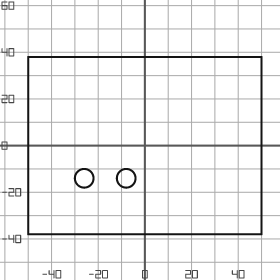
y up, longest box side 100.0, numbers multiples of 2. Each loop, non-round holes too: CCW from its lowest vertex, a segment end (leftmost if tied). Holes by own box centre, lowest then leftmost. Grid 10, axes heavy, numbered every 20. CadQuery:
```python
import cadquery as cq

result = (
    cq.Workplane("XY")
    .moveTo(-50.0, -38.0)
    .lineTo(50.0, -38.0)
    .lineTo(50.0, 38.0)
    .lineTo(-50.0, 38.0)
    .close()
    .moveTo(-26.0, -14.0)
    .circle(4.0)
    .moveTo(-8.0, -14.0)
    .circle(4.0)
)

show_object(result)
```